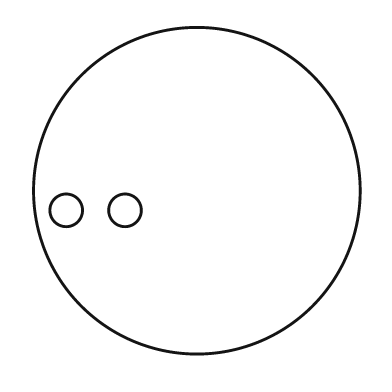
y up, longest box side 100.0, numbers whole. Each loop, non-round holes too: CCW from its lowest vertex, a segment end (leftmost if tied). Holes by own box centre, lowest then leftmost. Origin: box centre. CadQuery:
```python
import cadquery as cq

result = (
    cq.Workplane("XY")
    .moveTo(0.0, 0.0)
    .circle(50.0)
    .moveTo(-40.0, -6.0)
    .circle(5.0)
    .moveTo(-22.0, -6.0)
    .circle(5.0)
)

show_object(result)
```